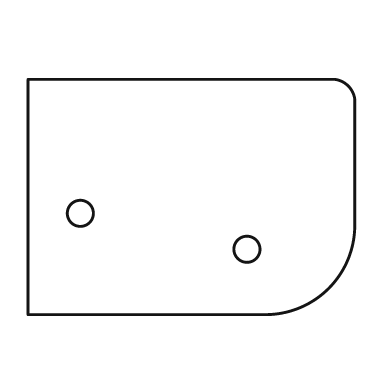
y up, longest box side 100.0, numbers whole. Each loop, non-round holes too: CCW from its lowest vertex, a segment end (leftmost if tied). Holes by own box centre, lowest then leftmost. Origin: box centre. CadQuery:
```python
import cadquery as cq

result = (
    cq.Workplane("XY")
    .moveTo(-50.0, -36.0)
    .lineTo(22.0, -36.0)
    .threePointArc((42.0, -28.0), (50.0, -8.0))
    .lineTo(50.0, 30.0)
    .threePointArc((48.0, 34.0), (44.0, 36.0))
    .lineTo(-50.0, 36.0)
    .close()
    .moveTo(17.0, -16.0)
    .circle(4.0)
    .moveTo(-34.0, -5.0)
    .circle(4.0)
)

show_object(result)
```